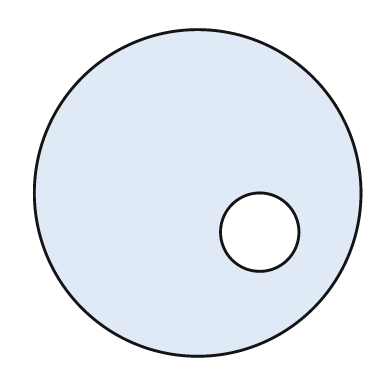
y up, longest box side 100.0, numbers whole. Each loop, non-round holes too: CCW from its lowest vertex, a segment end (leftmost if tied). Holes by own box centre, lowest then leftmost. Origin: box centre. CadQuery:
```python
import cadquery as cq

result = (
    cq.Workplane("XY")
    .moveTo(0.0, 0.0)
    .circle(50.0)
    .moveTo(19.0, -12.0)
    .circle(12.0)
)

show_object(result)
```